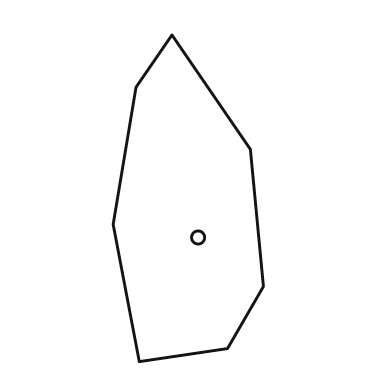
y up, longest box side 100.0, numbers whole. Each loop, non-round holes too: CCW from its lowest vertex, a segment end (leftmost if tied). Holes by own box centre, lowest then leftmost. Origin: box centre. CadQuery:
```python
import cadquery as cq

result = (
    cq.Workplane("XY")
    .moveTo(-15.0, -50.0)
    .lineTo(12.0, -46.0)
    .lineTo(23.0, -27.0)
    .lineTo(19.0, 15.0)
    .lineTo(-5.0, 50.0)
    .lineTo(-16.0, 34.0)
    .lineTo(-23.0, -8.0)
    .close()
    .moveTo(3.0, -12.0)
    .circle(2.0)
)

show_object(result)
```